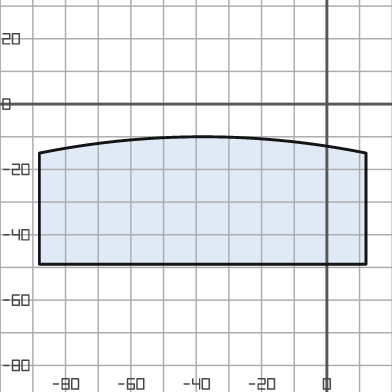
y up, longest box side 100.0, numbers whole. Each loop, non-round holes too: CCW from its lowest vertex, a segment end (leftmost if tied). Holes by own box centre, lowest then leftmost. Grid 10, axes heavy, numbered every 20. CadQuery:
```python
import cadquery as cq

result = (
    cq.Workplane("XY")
    .moveTo(-88.0, -49.0)
    .lineTo(12.0, -49.0)
    .lineTo(12.0, -15.0)
    .threePointArc((-38.0, -10.0), (-88.0, -15.0))
    .close()
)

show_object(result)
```